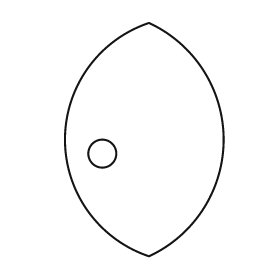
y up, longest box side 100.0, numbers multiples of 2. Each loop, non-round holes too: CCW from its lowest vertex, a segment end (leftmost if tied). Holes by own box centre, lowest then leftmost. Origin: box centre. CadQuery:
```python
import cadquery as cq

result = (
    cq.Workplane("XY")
    .moveTo(2.0, -50.0)
    .threePointArc((34.0, 0.0), (2.0, 50.0))
    .threePointArc((-34.0, 0.0), (2.0, -50.0))
    .close()
    .moveTo(-18.0, -6.0)
    .circle(6.0)
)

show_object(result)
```